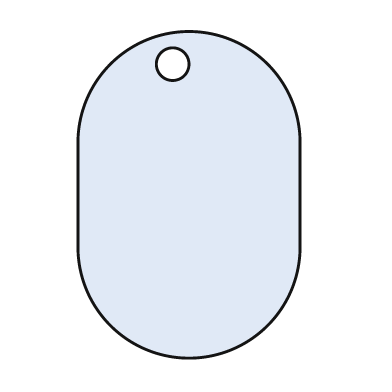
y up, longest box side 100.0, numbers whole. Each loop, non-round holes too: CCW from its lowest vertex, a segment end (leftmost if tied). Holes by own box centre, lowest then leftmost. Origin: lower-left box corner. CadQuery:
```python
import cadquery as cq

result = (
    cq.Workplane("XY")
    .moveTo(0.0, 34.0)
    .threePointArc((34.0, 0.0), (68.0, 34.0))
    .lineTo(68.0, 66.0)
    .threePointArc((34.0, 100.0), (0.0, 66.0))
    .close()
    .moveTo(29.0, 90.0)
    .circle(5.0)
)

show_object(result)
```